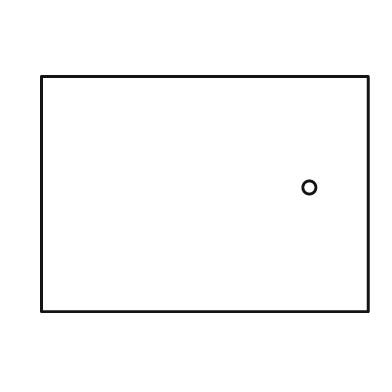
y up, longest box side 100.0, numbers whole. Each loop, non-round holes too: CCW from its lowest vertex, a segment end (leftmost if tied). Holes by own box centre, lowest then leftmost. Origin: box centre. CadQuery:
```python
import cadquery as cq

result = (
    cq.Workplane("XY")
    .moveTo(-50.0, -36.0)
    .lineTo(50.0, -36.0)
    .lineTo(50.0, 36.0)
    .lineTo(-50.0, 36.0)
    .close()
    .moveTo(32.0, 2.0)
    .circle(2.0)
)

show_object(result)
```